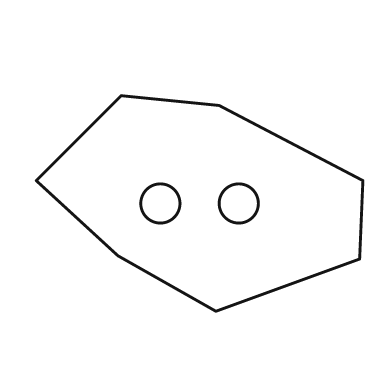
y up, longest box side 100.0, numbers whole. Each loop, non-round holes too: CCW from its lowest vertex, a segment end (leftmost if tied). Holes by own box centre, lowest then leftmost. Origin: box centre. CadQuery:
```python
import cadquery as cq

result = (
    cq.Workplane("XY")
    .moveTo(5.0, -33.0)
    .lineTo(49.0, -17.0)
    .lineTo(50.0, 7.0)
    .lineTo(6.0, 30.0)
    .lineTo(-24.0, 33.0)
    .lineTo(-50.0, 7.0)
    .lineTo(-25.0, -16.0)
    .close()
    .moveTo(-12.0, 0.0)
    .circle(6.0)
    .moveTo(12.0, 0.0)
    .circle(6.0)
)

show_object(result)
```